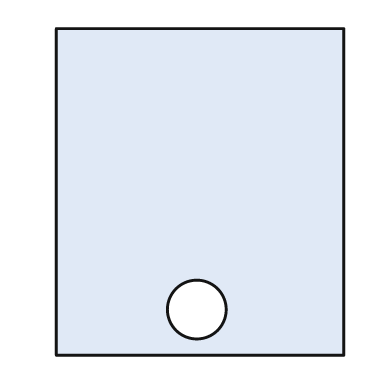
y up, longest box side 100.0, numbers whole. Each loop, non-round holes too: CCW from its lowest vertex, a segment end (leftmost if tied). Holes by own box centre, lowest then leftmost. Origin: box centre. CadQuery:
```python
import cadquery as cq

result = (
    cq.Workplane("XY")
    .moveTo(-44.0, -50.0)
    .lineTo(44.0, -50.0)
    .lineTo(44.0, 50.0)
    .lineTo(-44.0, 50.0)
    .close()
    .moveTo(-1.0, -36.0)
    .circle(9.0)
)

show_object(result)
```